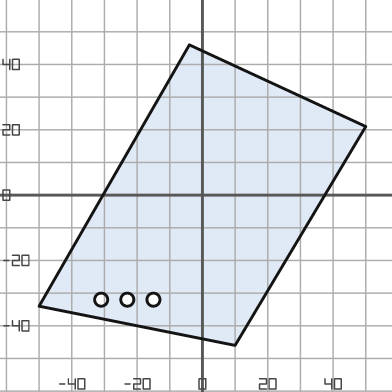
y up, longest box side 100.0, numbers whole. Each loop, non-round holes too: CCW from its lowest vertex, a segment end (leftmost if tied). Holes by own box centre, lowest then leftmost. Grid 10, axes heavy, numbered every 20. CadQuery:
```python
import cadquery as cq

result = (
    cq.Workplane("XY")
    .moveTo(10.0, -46.0)
    .lineTo(50.0, 21.0)
    .lineTo(-4.0, 46.0)
    .lineTo(-50.0, -34.0)
    .close()
    .moveTo(-31.0, -32.0)
    .circle(2.0)
    .moveTo(-23.0, -32.0)
    .circle(2.0)
    .moveTo(-15.0, -32.0)
    .circle(2.0)
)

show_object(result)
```